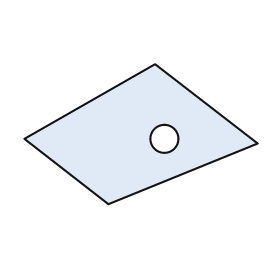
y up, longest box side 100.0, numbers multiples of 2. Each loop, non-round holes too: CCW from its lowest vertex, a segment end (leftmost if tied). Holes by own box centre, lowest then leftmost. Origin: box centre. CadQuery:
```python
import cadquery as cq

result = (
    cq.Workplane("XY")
    .moveTo(-14.0, -30.0)
    .lineTo(50.0, -4.0)
    .lineTo(6.0, 30.0)
    .lineTo(-50.0, -2.0)
    .close()
    .moveTo(10.0, -2.0)
    .circle(6.0)
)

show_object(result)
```